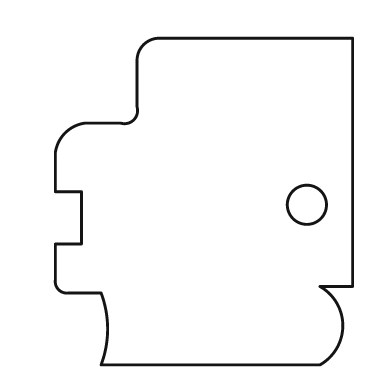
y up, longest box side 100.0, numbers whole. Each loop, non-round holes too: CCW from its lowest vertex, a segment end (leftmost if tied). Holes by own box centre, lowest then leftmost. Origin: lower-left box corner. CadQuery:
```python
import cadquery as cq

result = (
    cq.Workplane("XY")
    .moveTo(14.0, 0.0)
    .lineTo(81.0, 0.0)
    .threePointArc((88.0, 12.0), (81.0, 24.0))
    .lineTo(91.0, 24.0)
    .lineTo(91.0, 100.0)
    .lineTo(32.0, 100.0)
    .threePointArc((27.0, 98.0), (25.0, 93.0))
    .lineTo(25.0, 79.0)
    .threePointArc((24.0, 75.0), (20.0, 74.0))
    .lineTo(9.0, 74.0)
    .threePointArc((3.0, 71.0), (0.0, 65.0))
    .lineTo(0.0, 53.0)
    .lineTo(8.0, 53.0)
    .lineTo(8.0, 37.0)
    .lineTo(0.0, 37.0)
    .lineTo(0.0, 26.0)
    .threePointArc((1.0, 23.0), (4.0, 22.0))
    .lineTo(14.0, 22.0)
    .threePointArc((16.0, 11.0), (14.0, 0.0))
    .close()
    .moveTo(77.0, 49.0)
    .circle(6.0)
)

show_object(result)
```